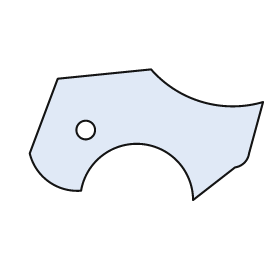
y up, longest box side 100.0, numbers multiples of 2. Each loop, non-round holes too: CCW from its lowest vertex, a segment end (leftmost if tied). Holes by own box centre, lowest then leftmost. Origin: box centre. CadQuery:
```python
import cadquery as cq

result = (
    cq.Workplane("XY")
    .moveTo(20.0, -28.0)
    .lineTo(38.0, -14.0)
    .threePointArc((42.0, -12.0), (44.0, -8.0))
    .lineTo(50.0, 14.0)
    .threePointArc((24.0, 14.0), (2.0, 28.0))
    .lineTo(-38.0, 24.0)
    .lineTo(-50.0, -8.0)
    .threePointArc((-42.0, -20.0), (-28.0, -24.0))
    .threePointArc((-2.0, -4.0), (20.0, -28.0))
    .close()
    .moveTo(-26.0, 2.0)
    .circle(4.0)
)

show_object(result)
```